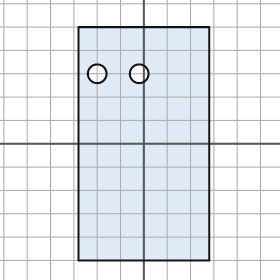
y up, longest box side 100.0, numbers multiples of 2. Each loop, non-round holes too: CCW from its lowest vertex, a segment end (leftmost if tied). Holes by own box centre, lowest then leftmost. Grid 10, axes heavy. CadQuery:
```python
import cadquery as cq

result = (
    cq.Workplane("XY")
    .moveTo(-28.0, -50.0)
    .lineTo(28.0, -50.0)
    .lineTo(28.0, 50.0)
    .lineTo(-28.0, 50.0)
    .close()
    .moveTo(-20.0, 30.0)
    .circle(4.0)
    .moveTo(-2.0, 30.0)
    .circle(4.0)
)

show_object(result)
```